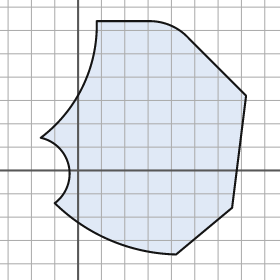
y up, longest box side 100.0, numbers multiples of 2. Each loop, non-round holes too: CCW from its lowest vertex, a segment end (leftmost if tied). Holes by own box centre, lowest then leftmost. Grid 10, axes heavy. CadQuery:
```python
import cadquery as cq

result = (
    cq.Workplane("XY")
    .moveTo(42.0, -36.0)
    .lineTo(66.0, -16.0)
    .lineTo(72.0, 32.0)
    .lineTo(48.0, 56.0)
    .threePointArc((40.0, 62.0), (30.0, 64.0))
    .lineTo(8.0, 64.0)
    .threePointArc((2.0, 36.0), (-16.0, 14.0))
    .threePointArc((-4.0, 2.0), (-10.0, -14.0))
    .threePointArc((14.0, -30.0), (42.0, -36.0))
    .close()
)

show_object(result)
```